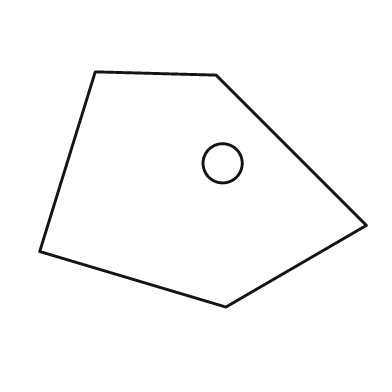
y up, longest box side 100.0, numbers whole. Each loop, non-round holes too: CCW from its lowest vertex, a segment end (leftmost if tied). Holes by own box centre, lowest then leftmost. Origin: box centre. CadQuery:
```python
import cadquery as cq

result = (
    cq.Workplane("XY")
    .moveTo(7.0, -36.0)
    .lineTo(50.0, -11.0)
    .lineTo(4.0, 35.0)
    .lineTo(-33.0, 36.0)
    .lineTo(-50.0, -19.0)
    .close()
    .moveTo(6.0, 8.0)
    .circle(6.0)
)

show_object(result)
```